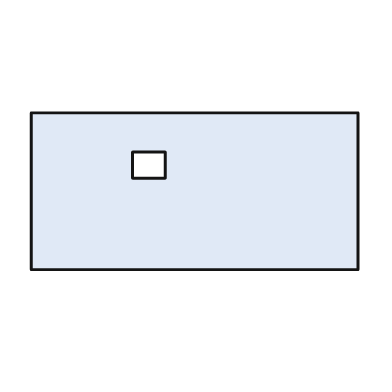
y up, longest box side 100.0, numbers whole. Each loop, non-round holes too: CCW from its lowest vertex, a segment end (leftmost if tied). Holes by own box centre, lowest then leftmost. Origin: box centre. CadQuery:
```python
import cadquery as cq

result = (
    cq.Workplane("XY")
    .moveTo(-50.0, -24.0)
    .lineTo(50.0, -24.0)
    .lineTo(50.0, 24.0)
    .lineTo(-50.0, 24.0)
    .close()
    .moveTo(-19.0, 4.0)
    .lineTo(-9.0, 4.0)
    .lineTo(-9.0, 12.0)
    .lineTo(-19.0, 12.0)
    .close()
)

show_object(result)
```